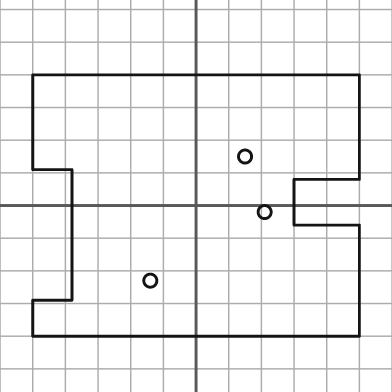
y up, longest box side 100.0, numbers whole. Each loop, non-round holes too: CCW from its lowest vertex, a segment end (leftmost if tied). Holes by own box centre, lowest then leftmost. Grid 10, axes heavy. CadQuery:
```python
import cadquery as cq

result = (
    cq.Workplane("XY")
    .moveTo(-50.0, -40.0)
    .lineTo(50.0, -40.0)
    .lineTo(50.0, -6.0)
    .lineTo(30.0, -6.0)
    .lineTo(30.0, 8.0)
    .lineTo(50.0, 8.0)
    .lineTo(50.0, 40.0)
    .lineTo(-50.0, 40.0)
    .lineTo(-50.0, 11.0)
    .lineTo(-38.0, 11.0)
    .lineTo(-38.0, -29.0)
    .lineTo(-50.0, -29.0)
    .close()
    .moveTo(-14.0, -23.0)
    .circle(2.0)
    .moveTo(21.0, -2.0)
    .circle(2.0)
    .moveTo(15.0, 15.0)
    .circle(2.0)
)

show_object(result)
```